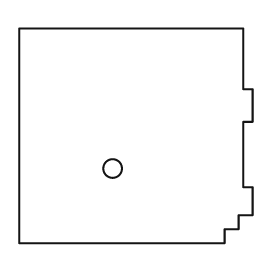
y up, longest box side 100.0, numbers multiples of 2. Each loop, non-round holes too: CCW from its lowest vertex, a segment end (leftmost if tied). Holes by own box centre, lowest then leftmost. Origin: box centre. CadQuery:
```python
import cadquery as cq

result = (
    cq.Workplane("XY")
    .moveTo(-50.0, -46.0)
    .lineTo(38.0, -46.0)
    .lineTo(38.0, -40.0)
    .lineTo(44.0, -40.0)
    .lineTo(44.0, -34.0)
    .lineTo(50.0, -34.0)
    .lineTo(50.0, -22.0)
    .lineTo(46.0, -22.0)
    .lineTo(46.0, 6.0)
    .lineTo(50.0, 6.0)
    .lineTo(50.0, 20.0)
    .lineTo(46.0, 20.0)
    .lineTo(46.0, 46.0)
    .lineTo(-50.0, 46.0)
    .close()
    .moveTo(-10.0, -14.0)
    .circle(4.0)
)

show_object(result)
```